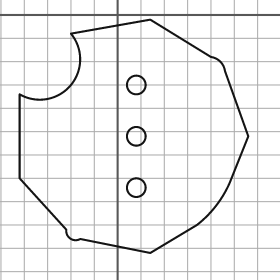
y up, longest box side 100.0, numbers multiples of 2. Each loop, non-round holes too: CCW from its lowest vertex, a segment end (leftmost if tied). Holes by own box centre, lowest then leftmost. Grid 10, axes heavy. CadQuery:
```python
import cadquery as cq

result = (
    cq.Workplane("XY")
    .moveTo(14.0, -102.0)
    .lineTo(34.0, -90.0)
    .threePointArc((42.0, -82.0), (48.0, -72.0))
    .lineTo(56.0, -52.0)
    .lineTo(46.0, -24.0)
    .threePointArc((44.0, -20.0), (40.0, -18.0))
    .lineTo(14.0, -2.0)
    .lineTo(-20.0, -8.0)
    .threePointArc((-20.0, -30.0), (-42.0, -34.0))
    .lineTo(-42.0, -70.0)
    .lineTo(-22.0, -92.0)
    .threePointArc((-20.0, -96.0), (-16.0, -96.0))
    .close()
    .moveTo(8.0, -74.0)
    .circle(4.0)
    .moveTo(8.0, -52.0)
    .circle(4.0)
    .moveTo(8.0, -30.0)
    .circle(4.0)
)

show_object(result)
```